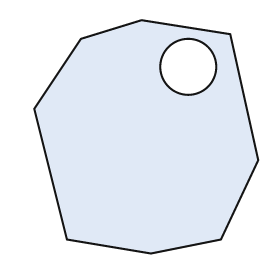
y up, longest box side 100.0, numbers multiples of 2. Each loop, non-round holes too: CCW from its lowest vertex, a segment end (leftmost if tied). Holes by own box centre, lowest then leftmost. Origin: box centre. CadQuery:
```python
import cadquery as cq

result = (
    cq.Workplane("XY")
    .moveTo(2.0, -50.0)
    .lineTo(32.0, -44.0)
    .lineTo(48.0, -10.0)
    .lineTo(36.0, 44.0)
    .lineTo(-2.0, 50.0)
    .lineTo(-28.0, 42.0)
    .lineTo(-48.0, 12.0)
    .lineTo(-34.0, -44.0)
    .close()
    .moveTo(18.0, 30.0)
    .circle(12.0)
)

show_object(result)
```